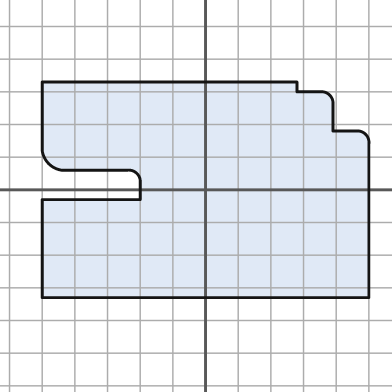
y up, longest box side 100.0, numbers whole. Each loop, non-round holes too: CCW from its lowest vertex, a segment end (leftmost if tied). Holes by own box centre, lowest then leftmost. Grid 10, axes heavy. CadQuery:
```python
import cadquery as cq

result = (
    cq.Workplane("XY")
    .moveTo(-50.0, -33.0)
    .lineTo(50.0, -33.0)
    .lineTo(50.0, 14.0)
    .threePointArc((49.0, 17.0), (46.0, 18.0))
    .lineTo(39.0, 18.0)
    .lineTo(39.0, 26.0)
    .threePointArc((38.0, 29.0), (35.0, 30.0))
    .lineTo(28.0, 30.0)
    .lineTo(28.0, 33.0)
    .lineTo(-50.0, 33.0)
    .lineTo(-50.0, 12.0)
    .threePointArc((-48.0, 8.0), (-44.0, 6.0))
    .lineTo(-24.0, 6.0)
    .threePointArc((-21.0, 5.0), (-20.0, 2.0))
    .lineTo(-20.0, -3.0)
    .lineTo(-50.0, -3.0)
    .close()
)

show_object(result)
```